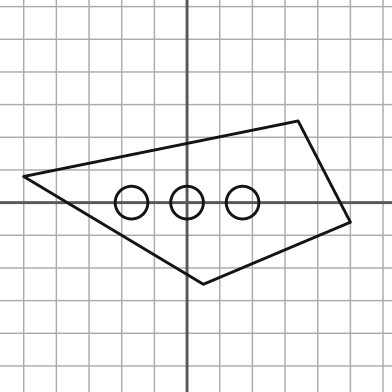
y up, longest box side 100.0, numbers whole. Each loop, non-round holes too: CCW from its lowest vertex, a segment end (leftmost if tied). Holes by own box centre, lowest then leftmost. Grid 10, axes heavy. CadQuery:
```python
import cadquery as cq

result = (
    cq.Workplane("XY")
    .moveTo(5.0, -25.0)
    .lineTo(50.0, -6.0)
    .lineTo(34.0, 25.0)
    .lineTo(-50.0, 8.0)
    .close()
    .moveTo(-17.0, 0.0)
    .circle(5.0)
    .moveTo(0.0, 0.0)
    .circle(5.0)
    .moveTo(17.0, 0.0)
    .circle(5.0)
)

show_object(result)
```